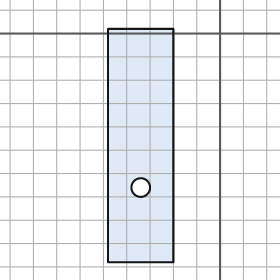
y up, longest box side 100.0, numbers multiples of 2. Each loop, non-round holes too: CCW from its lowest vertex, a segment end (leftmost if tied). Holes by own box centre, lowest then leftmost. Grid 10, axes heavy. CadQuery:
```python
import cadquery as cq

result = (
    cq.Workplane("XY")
    .moveTo(-48.0, -98.0)
    .lineTo(-20.0, -98.0)
    .lineTo(-20.0, 2.0)
    .lineTo(-48.0, 2.0)
    .close()
    .moveTo(-34.0, -66.0)
    .circle(4.0)
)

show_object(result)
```